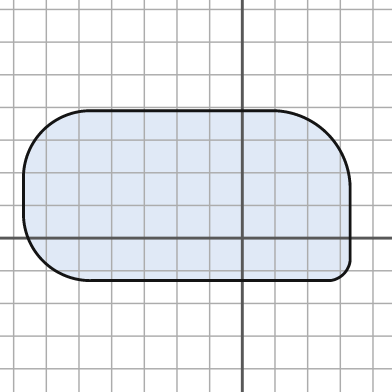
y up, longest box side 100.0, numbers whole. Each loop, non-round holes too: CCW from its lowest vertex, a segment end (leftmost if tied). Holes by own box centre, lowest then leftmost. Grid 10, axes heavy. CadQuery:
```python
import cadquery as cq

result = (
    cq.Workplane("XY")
    .moveTo(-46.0, -13.0)
    .lineTo(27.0, -13.0)
    .threePointArc((31.0, -11.0), (33.0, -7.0))
    .lineTo(33.0, 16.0)
    .threePointArc((26.0, 32.0), (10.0, 39.0))
    .lineTo(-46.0, 39.0)
    .threePointArc((-61.0, 33.0), (-67.0, 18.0))
    .lineTo(-67.0, 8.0)
    .threePointArc((-61.0, -7.0), (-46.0, -13.0))
    .close()
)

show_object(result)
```